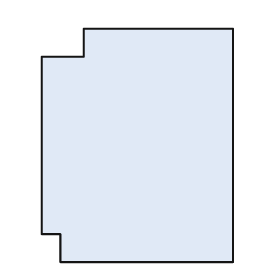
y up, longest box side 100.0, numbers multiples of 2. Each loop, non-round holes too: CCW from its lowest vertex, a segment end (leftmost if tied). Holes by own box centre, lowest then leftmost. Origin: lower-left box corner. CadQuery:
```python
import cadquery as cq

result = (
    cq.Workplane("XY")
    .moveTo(8.0, 0.0)
    .lineTo(82.0, 0.0)
    .lineTo(82.0, 100.0)
    .lineTo(18.0, 100.0)
    .lineTo(18.0, 88.0)
    .lineTo(0.0, 88.0)
    .lineTo(0.0, 12.0)
    .lineTo(8.0, 12.0)
    .close()
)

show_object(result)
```